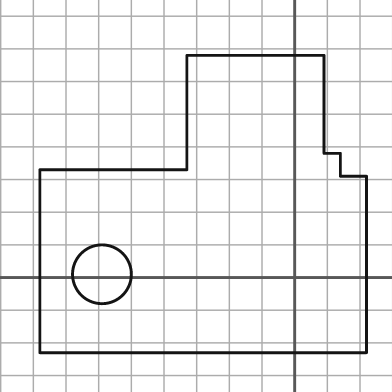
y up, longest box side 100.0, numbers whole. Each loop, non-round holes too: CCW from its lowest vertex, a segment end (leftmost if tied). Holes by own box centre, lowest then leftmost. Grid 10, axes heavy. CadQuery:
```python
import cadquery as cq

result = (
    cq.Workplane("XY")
    .moveTo(-78.0, -23.0)
    .lineTo(22.0, -23.0)
    .lineTo(22.0, 31.0)
    .lineTo(14.0, 31.0)
    .lineTo(14.0, 38.0)
    .lineTo(9.0, 38.0)
    .lineTo(9.0, 68.0)
    .lineTo(-33.0, 68.0)
    .lineTo(-33.0, 33.0)
    .lineTo(-78.0, 33.0)
    .close()
    .moveTo(-59.0, 1.0)
    .circle(9.0)
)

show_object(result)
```